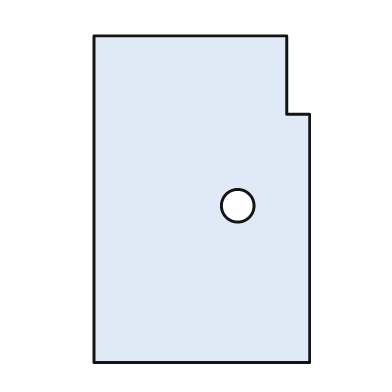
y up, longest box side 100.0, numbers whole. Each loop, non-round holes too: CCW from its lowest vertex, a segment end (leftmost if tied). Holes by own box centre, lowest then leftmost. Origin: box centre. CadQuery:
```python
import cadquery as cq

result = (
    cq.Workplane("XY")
    .moveTo(-33.0, -50.0)
    .lineTo(33.0, -50.0)
    .lineTo(33.0, 26.0)
    .lineTo(26.0, 26.0)
    .lineTo(26.0, 50.0)
    .lineTo(-33.0, 50.0)
    .close()
    .moveTo(11.0, -2.0)
    .circle(5.0)
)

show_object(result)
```